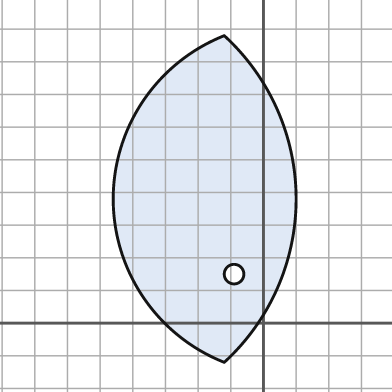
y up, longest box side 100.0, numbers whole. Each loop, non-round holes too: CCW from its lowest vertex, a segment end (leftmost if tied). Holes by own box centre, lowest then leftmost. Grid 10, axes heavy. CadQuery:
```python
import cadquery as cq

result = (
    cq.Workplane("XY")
    .moveTo(-12.0, -12.0)
    .threePointArc((10.0, 38.0), (-12.0, 88.0))
    .threePointArc((-46.0, 38.0), (-12.0, -12.0))
    .close()
    .moveTo(-9.0, 15.0)
    .circle(3.0)
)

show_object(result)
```